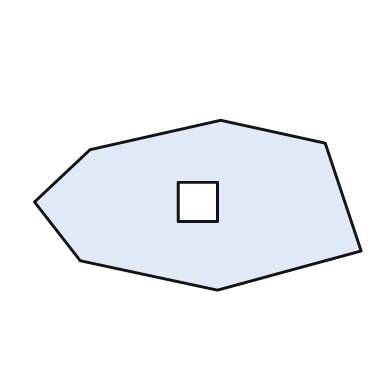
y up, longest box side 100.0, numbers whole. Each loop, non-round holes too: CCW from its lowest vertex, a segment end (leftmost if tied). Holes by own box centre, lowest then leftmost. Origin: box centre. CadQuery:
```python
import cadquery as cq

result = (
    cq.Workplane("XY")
    .moveTo(6.0, -26.0)
    .lineTo(50.0, -14.0)
    .lineTo(39.0, 19.0)
    .lineTo(7.0, 26.0)
    .lineTo(-33.0, 17.0)
    .lineTo(-50.0, 1.0)
    .lineTo(-36.0, -17.0)
    .close()
    .moveTo(-6.0, -5.0)
    .lineTo(6.0, -5.0)
    .lineTo(6.0, 7.0)
    .lineTo(-6.0, 7.0)
    .close()
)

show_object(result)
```